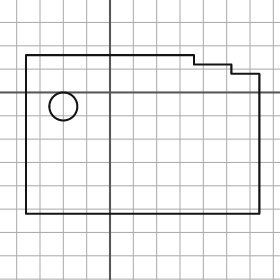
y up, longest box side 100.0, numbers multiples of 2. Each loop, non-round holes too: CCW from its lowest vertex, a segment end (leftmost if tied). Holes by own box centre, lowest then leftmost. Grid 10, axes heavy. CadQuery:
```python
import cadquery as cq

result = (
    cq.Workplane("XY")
    .moveTo(-36.0, -52.0)
    .lineTo(64.0, -52.0)
    .lineTo(64.0, 8.0)
    .lineTo(52.0, 8.0)
    .lineTo(52.0, 12.0)
    .lineTo(36.0, 12.0)
    .lineTo(36.0, 16.0)
    .lineTo(-36.0, 16.0)
    .close()
    .moveTo(-20.0, -6.0)
    .circle(6.0)
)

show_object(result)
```